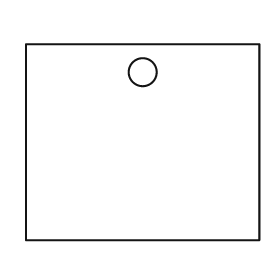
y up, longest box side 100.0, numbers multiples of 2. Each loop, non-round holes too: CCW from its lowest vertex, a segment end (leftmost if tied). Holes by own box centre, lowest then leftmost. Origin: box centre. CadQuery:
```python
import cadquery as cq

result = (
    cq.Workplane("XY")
    .moveTo(-50.0, -42.0)
    .lineTo(50.0, -42.0)
    .lineTo(50.0, 42.0)
    .lineTo(-50.0, 42.0)
    .close()
    .moveTo(0.0, 30.0)
    .circle(6.0)
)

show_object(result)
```